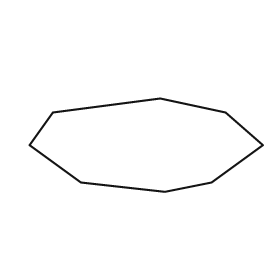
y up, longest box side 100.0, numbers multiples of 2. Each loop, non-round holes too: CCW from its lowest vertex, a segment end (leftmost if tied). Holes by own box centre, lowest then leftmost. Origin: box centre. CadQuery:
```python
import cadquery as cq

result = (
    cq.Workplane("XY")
    .moveTo(8.0, -20.0)
    .lineTo(28.0, -16.0)
    .lineTo(50.0, 0.0)
    .lineTo(34.0, 14.0)
    .lineTo(6.0, 20.0)
    .lineTo(-40.0, 14.0)
    .lineTo(-50.0, 0.0)
    .lineTo(-28.0, -16.0)
    .close()
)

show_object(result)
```